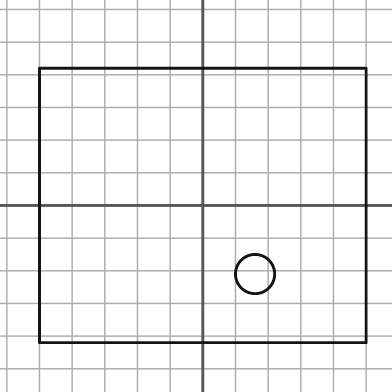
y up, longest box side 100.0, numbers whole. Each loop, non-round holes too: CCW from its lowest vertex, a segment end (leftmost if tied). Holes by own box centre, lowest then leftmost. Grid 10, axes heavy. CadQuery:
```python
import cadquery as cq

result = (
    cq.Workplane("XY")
    .moveTo(-50.0, -42.0)
    .lineTo(50.0, -42.0)
    .lineTo(50.0, 42.0)
    .lineTo(-50.0, 42.0)
    .close()
    .moveTo(16.0, -21.0)
    .circle(6.0)
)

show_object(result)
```